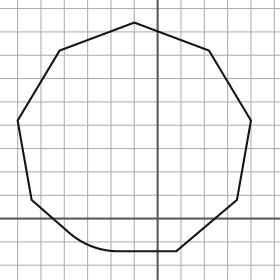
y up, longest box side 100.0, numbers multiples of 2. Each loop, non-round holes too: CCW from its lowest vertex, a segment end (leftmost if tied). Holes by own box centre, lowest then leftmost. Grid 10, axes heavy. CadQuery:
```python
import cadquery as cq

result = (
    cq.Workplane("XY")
    .moveTo(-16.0, -14.0)
    .lineTo(8.0, -14.0)
    .lineTo(34.0, 8.0)
    .lineTo(40.0, 42.0)
    .lineTo(22.0, 72.0)
    .lineTo(-10.0, 84.0)
    .lineTo(-42.0, 72.0)
    .lineTo(-60.0, 42.0)
    .lineTo(-54.0, 8.0)
    .lineTo(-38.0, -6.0)
    .threePointArc((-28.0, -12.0), (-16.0, -14.0))
    .close()
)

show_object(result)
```